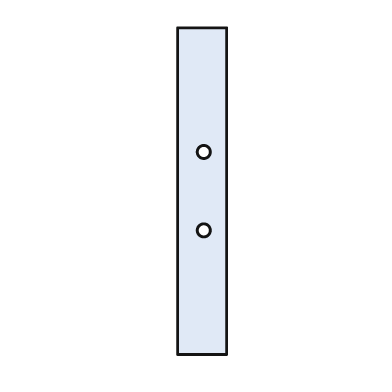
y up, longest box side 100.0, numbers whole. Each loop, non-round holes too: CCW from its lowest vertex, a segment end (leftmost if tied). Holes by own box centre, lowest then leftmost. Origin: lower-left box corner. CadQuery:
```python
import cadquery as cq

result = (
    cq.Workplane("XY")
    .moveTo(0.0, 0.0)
    .lineTo(15.0, 0.0)
    .lineTo(15.0, 100.0)
    .lineTo(0.0, 100.0)
    .close()
    .moveTo(8.0, 38.0)
    .circle(2.0)
    .moveTo(8.0, 62.0)
    .circle(2.0)
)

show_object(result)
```